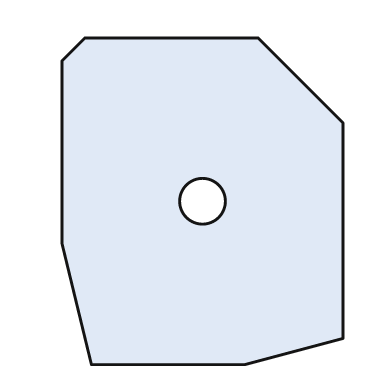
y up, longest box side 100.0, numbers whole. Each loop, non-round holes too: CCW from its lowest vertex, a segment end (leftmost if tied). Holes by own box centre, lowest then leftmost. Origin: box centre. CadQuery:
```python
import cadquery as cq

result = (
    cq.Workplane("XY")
    .moveTo(-34.0, -50.0)
    .lineTo(13.0, -50.0)
    .lineTo(43.0, -42.0)
    .lineTo(43.0, 24.0)
    .lineTo(17.0, 50.0)
    .lineTo(-36.0, 50.0)
    .lineTo(-43.0, 43.0)
    .lineTo(-43.0, -13.0)
    .close()
    .moveTo(0.0, 0.0)
    .circle(7.0)
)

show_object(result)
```